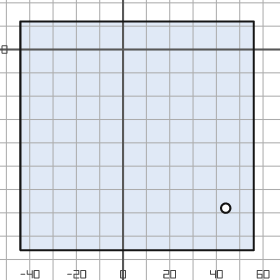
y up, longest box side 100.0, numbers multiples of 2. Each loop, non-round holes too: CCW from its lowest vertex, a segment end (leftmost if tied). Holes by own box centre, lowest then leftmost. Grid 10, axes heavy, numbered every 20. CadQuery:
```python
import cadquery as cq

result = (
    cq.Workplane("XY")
    .moveTo(-44.0, -86.0)
    .lineTo(56.0, -86.0)
    .lineTo(56.0, 12.0)
    .lineTo(-44.0, 12.0)
    .close()
    .moveTo(44.0, -68.0)
    .circle(2.0)
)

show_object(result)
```